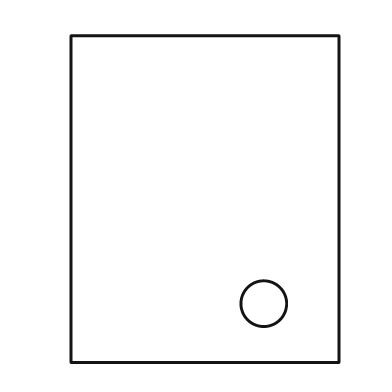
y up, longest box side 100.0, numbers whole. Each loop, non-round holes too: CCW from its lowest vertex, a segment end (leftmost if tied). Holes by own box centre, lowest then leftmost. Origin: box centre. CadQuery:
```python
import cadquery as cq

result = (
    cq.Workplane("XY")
    .moveTo(-41.0, -50.0)
    .lineTo(41.0, -50.0)
    .lineTo(41.0, 50.0)
    .lineTo(-41.0, 50.0)
    .close()
    .moveTo(18.0, -32.0)
    .circle(7.0)
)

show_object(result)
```